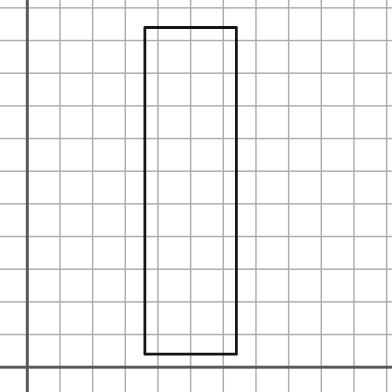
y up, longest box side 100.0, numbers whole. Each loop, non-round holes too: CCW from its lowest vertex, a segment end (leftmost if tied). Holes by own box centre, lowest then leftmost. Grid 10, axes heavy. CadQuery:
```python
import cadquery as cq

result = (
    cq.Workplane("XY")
    .moveTo(36.0, 4.0)
    .lineTo(64.0, 4.0)
    .lineTo(64.0, 104.0)
    .lineTo(36.0, 104.0)
    .close()
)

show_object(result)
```